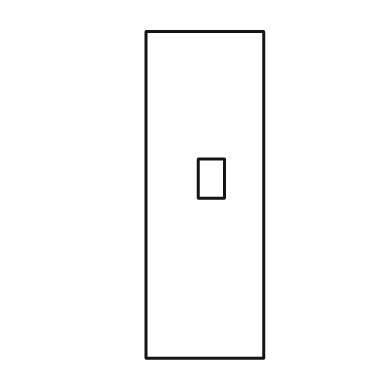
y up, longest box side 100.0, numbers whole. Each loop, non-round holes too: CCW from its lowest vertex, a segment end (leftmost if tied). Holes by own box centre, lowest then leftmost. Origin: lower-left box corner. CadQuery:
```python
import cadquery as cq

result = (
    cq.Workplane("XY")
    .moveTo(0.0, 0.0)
    .lineTo(36.0, 0.0)
    .lineTo(36.0, 100.0)
    .lineTo(0.0, 100.0)
    .close()
    .moveTo(16.0, 49.0)
    .lineTo(24.0, 49.0)
    .lineTo(24.0, 61.0)
    .lineTo(16.0, 61.0)
    .close()
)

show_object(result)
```